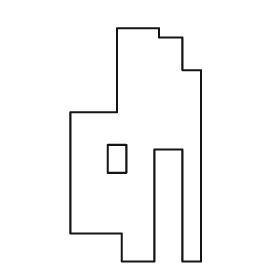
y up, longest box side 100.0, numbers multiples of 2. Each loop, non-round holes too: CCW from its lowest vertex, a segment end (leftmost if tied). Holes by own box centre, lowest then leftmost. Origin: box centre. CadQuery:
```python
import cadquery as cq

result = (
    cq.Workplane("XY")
    .moveTo(-6.0, -50.0)
    .lineTo(8.0, -50.0)
    .lineTo(8.0, -2.0)
    .lineTo(20.0, -2.0)
    .lineTo(20.0, -50.0)
    .lineTo(28.0, -50.0)
    .lineTo(28.0, 32.0)
    .lineTo(20.0, 32.0)
    .lineTo(20.0, 46.0)
    .lineTo(10.0, 46.0)
    .lineTo(10.0, 50.0)
    .lineTo(-8.0, 50.0)
    .lineTo(-8.0, 14.0)
    .lineTo(-28.0, 14.0)
    .lineTo(-28.0, -38.0)
    .lineTo(-6.0, -38.0)
    .close()
    .moveTo(-12.0, -12.0)
    .lineTo(-4.0, -12.0)
    .lineTo(-4.0, 0.0)
    .lineTo(-12.0, 0.0)
    .close()
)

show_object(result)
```